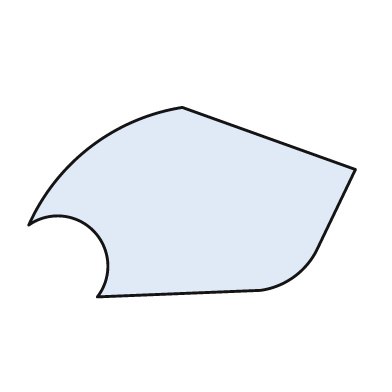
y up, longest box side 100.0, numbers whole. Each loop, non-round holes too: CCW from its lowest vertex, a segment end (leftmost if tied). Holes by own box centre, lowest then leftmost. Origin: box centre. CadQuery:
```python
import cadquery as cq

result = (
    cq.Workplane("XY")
    .moveTo(-29.0, -29.0)
    .lineTo(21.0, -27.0)
    .threePointArc((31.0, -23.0), (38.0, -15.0))
    .lineTo(50.0, 10.0)
    .lineTo(-3.0, 29.0)
    .threePointArc((-31.0, 17.0), (-50.0, -7.0))
    .threePointArc((-30.0, -9.0), (-29.0, -29.0))
    .close()
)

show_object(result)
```